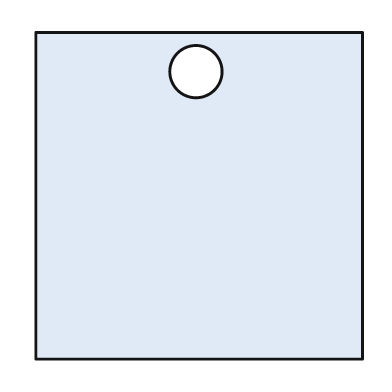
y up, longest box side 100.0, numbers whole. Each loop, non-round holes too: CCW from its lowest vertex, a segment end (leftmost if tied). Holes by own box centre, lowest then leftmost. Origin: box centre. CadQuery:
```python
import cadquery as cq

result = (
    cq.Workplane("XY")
    .moveTo(-50.0, -50.0)
    .lineTo(50.0, -50.0)
    .lineTo(50.0, 50.0)
    .lineTo(-50.0, 50.0)
    .close()
    .moveTo(-1.0, 38.0)
    .circle(8.0)
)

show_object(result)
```